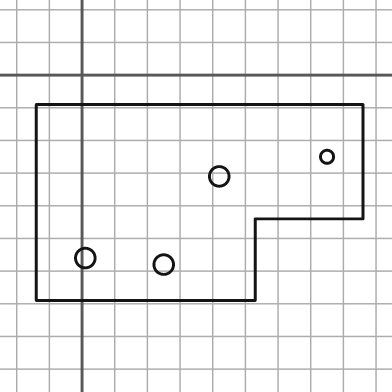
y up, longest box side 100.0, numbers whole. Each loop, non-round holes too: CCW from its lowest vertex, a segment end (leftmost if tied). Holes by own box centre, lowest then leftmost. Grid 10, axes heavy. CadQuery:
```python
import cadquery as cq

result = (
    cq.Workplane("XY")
    .moveTo(-14.0, -69.0)
    .lineTo(53.0, -69.0)
    .lineTo(53.0, -44.0)
    .lineTo(86.0, -44.0)
    .lineTo(86.0, -9.0)
    .lineTo(-14.0, -9.0)
    .close()
    .moveTo(25.0, -58.0)
    .circle(3.0)
    .moveTo(1.0, -56.0)
    .circle(3.0)
    .moveTo(42.0, -31.0)
    .circle(3.0)
    .moveTo(75.0, -25.0)
    .circle(2.0)
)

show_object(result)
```